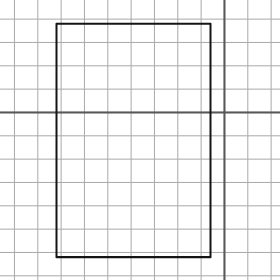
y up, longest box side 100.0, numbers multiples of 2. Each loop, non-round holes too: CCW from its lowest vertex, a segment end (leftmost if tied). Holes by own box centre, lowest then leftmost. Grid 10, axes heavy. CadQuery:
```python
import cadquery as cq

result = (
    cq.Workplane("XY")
    .moveTo(-72.0, -62.0)
    .lineTo(-6.0, -62.0)
    .lineTo(-6.0, 38.0)
    .lineTo(-72.0, 38.0)
    .close()
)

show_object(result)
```